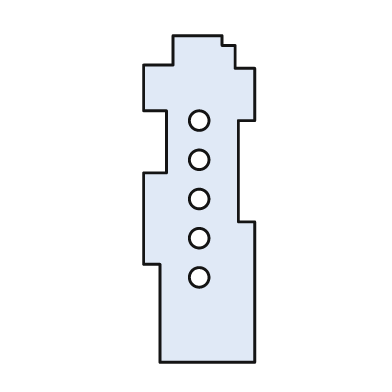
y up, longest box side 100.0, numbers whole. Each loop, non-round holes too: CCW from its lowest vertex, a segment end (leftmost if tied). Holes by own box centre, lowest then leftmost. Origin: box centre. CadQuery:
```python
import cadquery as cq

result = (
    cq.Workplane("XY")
    .moveTo(-12.0, -50.0)
    .lineTo(17.0, -50.0)
    .lineTo(17.0, -7.0)
    .lineTo(12.0, -7.0)
    .lineTo(12.0, 24.0)
    .lineTo(17.0, 24.0)
    .lineTo(17.0, 40.0)
    .lineTo(11.0, 40.0)
    .lineTo(11.0, 47.0)
    .lineTo(7.0, 47.0)
    .lineTo(7.0, 50.0)
    .lineTo(-8.0, 50.0)
    .lineTo(-8.0, 41.0)
    .lineTo(-17.0, 41.0)
    .lineTo(-17.0, 27.0)
    .lineTo(-10.0, 27.0)
    .lineTo(-10.0, 8.0)
    .lineTo(-17.0, 8.0)
    .lineTo(-17.0, -20.0)
    .lineTo(-12.0, -20.0)
    .close()
    .moveTo(0.0, -24.0)
    .circle(3.0)
    .moveTo(0.0, -12.0)
    .circle(3.0)
    .moveTo(0.0, 0.0)
    .circle(3.0)
    .moveTo(0.0, 12.0)
    .circle(3.0)
    .moveTo(0.0, 24.0)
    .circle(3.0)
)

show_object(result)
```